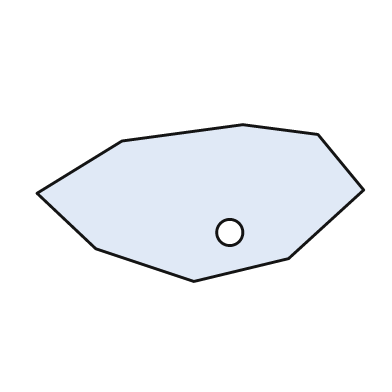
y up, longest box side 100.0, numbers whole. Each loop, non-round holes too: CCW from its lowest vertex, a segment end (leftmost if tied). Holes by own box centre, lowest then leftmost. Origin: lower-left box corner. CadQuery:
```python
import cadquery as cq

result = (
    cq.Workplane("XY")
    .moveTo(48.0, 0.0)
    .lineTo(77.0, 7.0)
    .lineTo(100.0, 28.0)
    .lineTo(86.0, 45.0)
    .lineTo(63.0, 48.0)
    .lineTo(26.0, 43.0)
    .lineTo(0.0, 27.0)
    .lineTo(18.0, 10.0)
    .close()
    .moveTo(59.0, 15.0)
    .circle(4.0)
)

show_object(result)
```